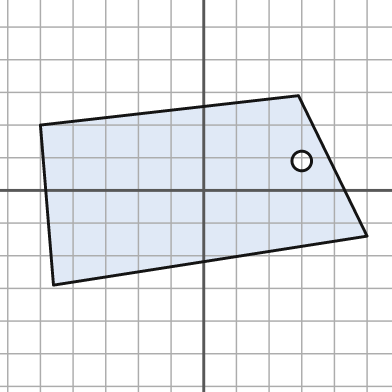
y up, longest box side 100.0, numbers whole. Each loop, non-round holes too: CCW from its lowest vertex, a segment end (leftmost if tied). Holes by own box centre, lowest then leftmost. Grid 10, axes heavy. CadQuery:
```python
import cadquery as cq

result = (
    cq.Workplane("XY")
    .moveTo(-46.0, -29.0)
    .lineTo(50.0, -14.0)
    .lineTo(29.0, 29.0)
    .lineTo(-50.0, 20.0)
    .close()
    .moveTo(30.0, 9.0)
    .circle(3.0)
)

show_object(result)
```